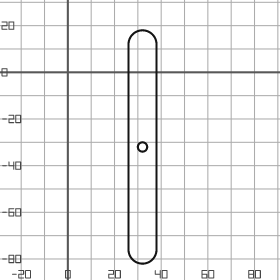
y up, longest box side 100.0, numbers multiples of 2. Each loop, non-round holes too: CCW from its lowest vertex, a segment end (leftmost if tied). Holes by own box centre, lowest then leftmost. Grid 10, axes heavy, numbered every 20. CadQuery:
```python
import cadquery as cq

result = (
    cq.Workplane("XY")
    .moveTo(26.0, -76.0)
    .threePointArc((32.0, -82.0), (38.0, -76.0))
    .lineTo(38.0, 12.0)
    .threePointArc((32.0, 18.0), (26.0, 12.0))
    .close()
    .moveTo(32.0, -32.0)
    .circle(2.0)
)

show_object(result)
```